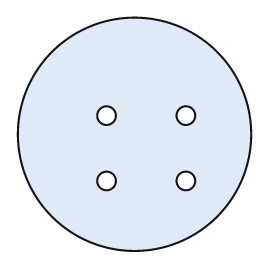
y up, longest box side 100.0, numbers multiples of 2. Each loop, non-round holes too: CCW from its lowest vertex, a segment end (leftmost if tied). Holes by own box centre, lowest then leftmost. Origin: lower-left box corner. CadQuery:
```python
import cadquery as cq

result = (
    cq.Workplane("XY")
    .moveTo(50.0, 50.0)
    .circle(50.0)
    .moveTo(38.0, 30.0)
    .circle(4.0)
    .moveTo(72.0, 30.0)
    .circle(4.0)
    .moveTo(38.0, 58.0)
    .circle(4.0)
    .moveTo(72.0, 58.0)
    .circle(4.0)
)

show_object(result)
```